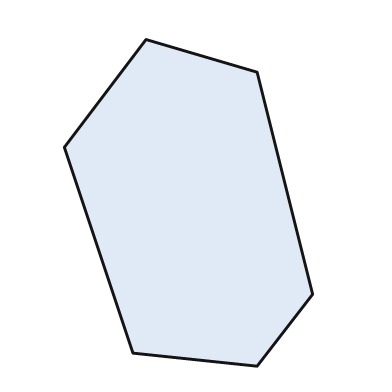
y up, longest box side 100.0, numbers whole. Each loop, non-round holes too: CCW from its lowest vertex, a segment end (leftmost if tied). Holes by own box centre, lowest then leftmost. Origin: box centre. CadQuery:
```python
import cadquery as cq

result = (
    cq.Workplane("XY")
    .moveTo(21.0, -50.0)
    .lineTo(38.0, -28.0)
    .lineTo(21.0, 40.0)
    .lineTo(-13.0, 50.0)
    .lineTo(-38.0, 17.0)
    .lineTo(-17.0, -46.0)
    .close()
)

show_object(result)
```